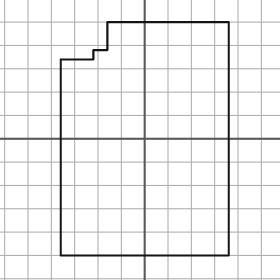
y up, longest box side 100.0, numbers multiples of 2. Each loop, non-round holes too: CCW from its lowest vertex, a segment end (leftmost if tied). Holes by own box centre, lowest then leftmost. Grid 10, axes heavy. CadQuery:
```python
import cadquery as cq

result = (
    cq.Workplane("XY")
    .moveTo(-36.0, -50.0)
    .lineTo(36.0, -50.0)
    .lineTo(36.0, 50.0)
    .lineTo(-16.0, 50.0)
    .lineTo(-16.0, 38.0)
    .lineTo(-22.0, 38.0)
    .lineTo(-22.0, 34.0)
    .lineTo(-36.0, 34.0)
    .close()
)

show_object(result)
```